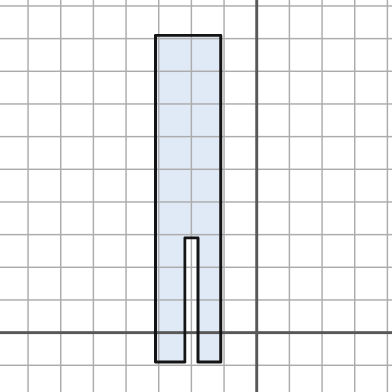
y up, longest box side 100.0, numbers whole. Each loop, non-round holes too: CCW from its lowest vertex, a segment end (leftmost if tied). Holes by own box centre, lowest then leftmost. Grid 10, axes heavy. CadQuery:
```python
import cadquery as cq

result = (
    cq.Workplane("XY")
    .moveTo(-31.0, -9.0)
    .lineTo(-22.0, -9.0)
    .lineTo(-22.0, 29.0)
    .lineTo(-18.0, 29.0)
    .lineTo(-18.0, -9.0)
    .lineTo(-11.0, -9.0)
    .lineTo(-11.0, 91.0)
    .lineTo(-31.0, 91.0)
    .close()
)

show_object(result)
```